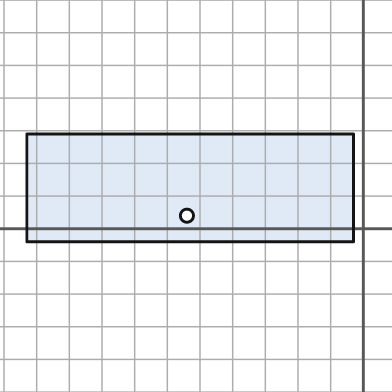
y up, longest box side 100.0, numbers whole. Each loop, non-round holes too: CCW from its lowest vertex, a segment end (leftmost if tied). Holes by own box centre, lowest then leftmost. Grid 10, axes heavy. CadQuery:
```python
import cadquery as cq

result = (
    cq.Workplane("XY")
    .moveTo(-103.0, -4.0)
    .lineTo(-3.0, -4.0)
    .lineTo(-3.0, 29.0)
    .lineTo(-103.0, 29.0)
    .close()
    .moveTo(-54.0, 4.0)
    .circle(2.0)
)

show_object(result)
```